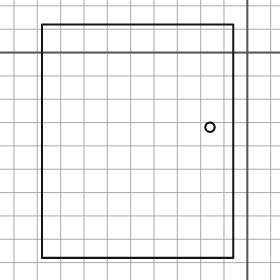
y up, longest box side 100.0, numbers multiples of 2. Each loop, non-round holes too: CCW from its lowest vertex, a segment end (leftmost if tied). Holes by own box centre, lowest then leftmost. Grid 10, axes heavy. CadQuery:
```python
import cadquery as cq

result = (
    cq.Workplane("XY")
    .moveTo(-88.0, -88.0)
    .lineTo(-6.0, -88.0)
    .lineTo(-6.0, 12.0)
    .lineTo(-88.0, 12.0)
    .close()
    .moveTo(-16.0, -32.0)
    .circle(2.0)
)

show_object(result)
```